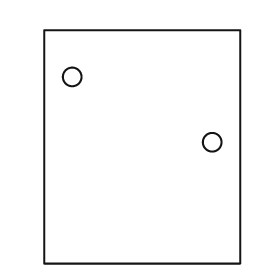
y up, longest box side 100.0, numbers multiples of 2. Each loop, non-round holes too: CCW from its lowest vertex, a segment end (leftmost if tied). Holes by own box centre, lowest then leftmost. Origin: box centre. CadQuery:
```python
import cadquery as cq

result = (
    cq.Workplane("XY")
    .moveTo(-42.0, -50.0)
    .lineTo(42.0, -50.0)
    .lineTo(42.0, 50.0)
    .lineTo(-42.0, 50.0)
    .close()
    .moveTo(30.0, 2.0)
    .circle(4.0)
    .moveTo(-30.0, 30.0)
    .circle(4.0)
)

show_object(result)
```